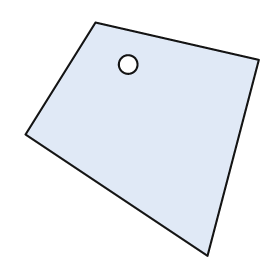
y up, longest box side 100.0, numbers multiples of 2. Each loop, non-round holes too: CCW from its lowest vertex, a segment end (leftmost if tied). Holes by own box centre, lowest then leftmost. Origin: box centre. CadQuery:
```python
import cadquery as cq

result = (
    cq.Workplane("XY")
    .moveTo(28.0, -50.0)
    .lineTo(50.0, 34.0)
    .lineTo(-20.0, 50.0)
    .lineTo(-50.0, 2.0)
    .close()
    .moveTo(-6.0, 32.0)
    .circle(4.0)
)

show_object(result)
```